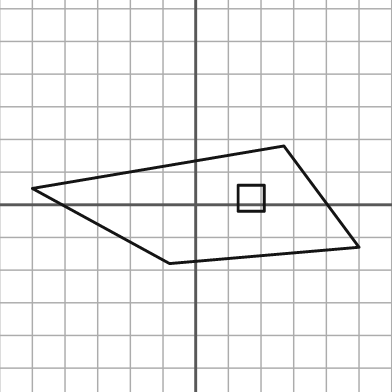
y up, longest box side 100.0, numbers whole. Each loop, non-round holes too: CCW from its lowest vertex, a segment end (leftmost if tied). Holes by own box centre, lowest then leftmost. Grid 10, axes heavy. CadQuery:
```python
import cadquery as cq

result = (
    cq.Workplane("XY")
    .moveTo(-8.0, -18.0)
    .lineTo(50.0, -13.0)
    .lineTo(27.0, 18.0)
    .lineTo(-50.0, 5.0)
    .close()
    .moveTo(13.0, -2.0)
    .lineTo(21.0, -2.0)
    .lineTo(21.0, 6.0)
    .lineTo(13.0, 6.0)
    .close()
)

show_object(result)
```